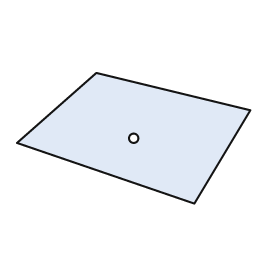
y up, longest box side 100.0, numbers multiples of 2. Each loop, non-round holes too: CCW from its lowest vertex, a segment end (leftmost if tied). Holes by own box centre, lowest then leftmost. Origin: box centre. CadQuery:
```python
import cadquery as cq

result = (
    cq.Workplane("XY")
    .moveTo(26.0, -28.0)
    .lineTo(50.0, 12.0)
    .lineTo(-16.0, 28.0)
    .lineTo(-50.0, -2.0)
    .close()
    .moveTo(0.0, 0.0)
    .circle(2.0)
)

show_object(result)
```